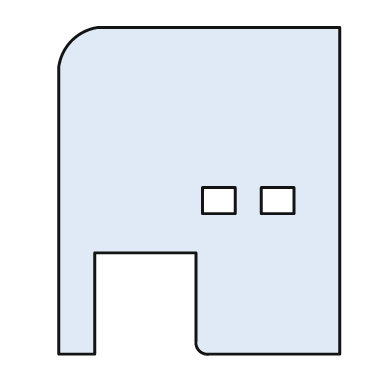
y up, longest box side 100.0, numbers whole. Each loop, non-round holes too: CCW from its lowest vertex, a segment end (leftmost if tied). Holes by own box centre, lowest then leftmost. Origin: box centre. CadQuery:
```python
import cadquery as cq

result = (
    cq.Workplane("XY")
    .moveTo(-43.0, -50.0)
    .lineTo(-32.0, -50.0)
    .lineTo(-32.0, -19.0)
    .lineTo(-1.0, -19.0)
    .lineTo(-1.0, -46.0)
    .threePointArc((0.0, -49.0), (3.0, -50.0))
    .lineTo(43.0, -50.0)
    .lineTo(43.0, 50.0)
    .lineTo(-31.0, 50.0)
    .threePointArc((-39.0, 46.0), (-43.0, 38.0))
    .close()
    .moveTo(1.0, -7.0)
    .lineTo(11.0, -7.0)
    .lineTo(11.0, 1.0)
    .lineTo(1.0, 1.0)
    .close()
    .moveTo(19.0, -7.0)
    .lineTo(29.0, -7.0)
    .lineTo(29.0, 1.0)
    .lineTo(19.0, 1.0)
    .close()
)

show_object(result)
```